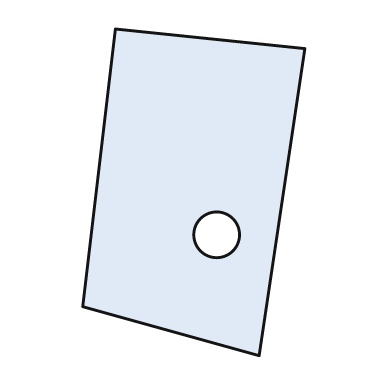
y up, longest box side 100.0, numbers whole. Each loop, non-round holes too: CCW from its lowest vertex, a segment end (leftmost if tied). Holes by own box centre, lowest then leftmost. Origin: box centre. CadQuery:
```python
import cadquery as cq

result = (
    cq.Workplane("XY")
    .moveTo(20.0, -50.0)
    .lineTo(34.0, 44.0)
    .lineTo(-24.0, 50.0)
    .lineTo(-34.0, -35.0)
    .close()
    .moveTo(7.0, -13.0)
    .circle(7.0)
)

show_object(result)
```